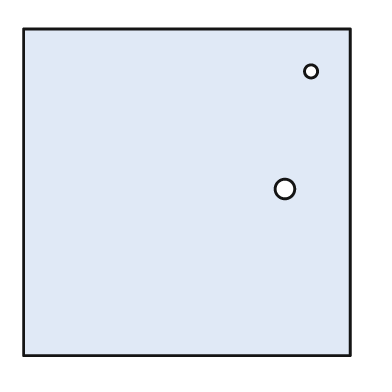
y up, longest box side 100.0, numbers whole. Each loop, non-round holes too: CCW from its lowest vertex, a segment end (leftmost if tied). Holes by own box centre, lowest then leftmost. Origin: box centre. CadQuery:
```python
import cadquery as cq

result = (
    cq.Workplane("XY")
    .moveTo(-50.0, -50.0)
    .lineTo(50.0, -50.0)
    .lineTo(50.0, 50.0)
    .lineTo(-50.0, 50.0)
    .close()
    .moveTo(30.0, 1.0)
    .circle(3.0)
    .moveTo(38.0, 37.0)
    .circle(2.0)
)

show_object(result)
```